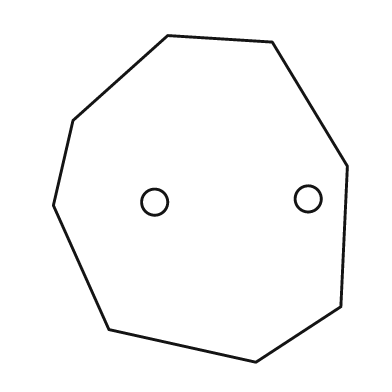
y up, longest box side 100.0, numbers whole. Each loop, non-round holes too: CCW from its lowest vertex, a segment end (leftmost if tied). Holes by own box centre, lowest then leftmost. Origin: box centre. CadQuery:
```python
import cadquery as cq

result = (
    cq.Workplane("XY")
    .moveTo(17.0, -50.0)
    .lineTo(43.0, -33.0)
    .lineTo(45.0, 10.0)
    .lineTo(22.0, 48.0)
    .lineTo(-10.0, 50.0)
    .lineTo(-39.0, 24.0)
    .lineTo(-45.0, -2.0)
    .lineTo(-28.0, -40.0)
    .close()
    .moveTo(-14.0, -1.0)
    .circle(4.0)
    .moveTo(33.0, 0.0)
    .circle(4.0)
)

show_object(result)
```